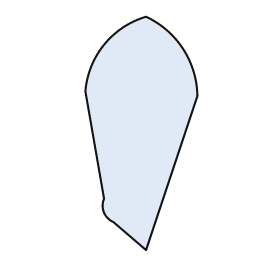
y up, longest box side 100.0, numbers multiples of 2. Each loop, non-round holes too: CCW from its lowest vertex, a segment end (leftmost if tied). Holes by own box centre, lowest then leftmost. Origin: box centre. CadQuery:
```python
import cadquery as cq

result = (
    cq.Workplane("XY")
    .moveTo(2.0, -50.0)
    .lineTo(24.0, 16.0)
    .threePointArc((18.0, 36.0), (2.0, 50.0))
    .threePointArc((-16.0, 38.0), (-24.0, 18.0))
    .lineTo(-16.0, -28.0)
    .threePointArc((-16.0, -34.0), (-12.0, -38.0))
    .close()
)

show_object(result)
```